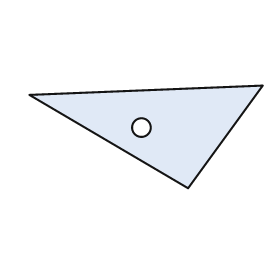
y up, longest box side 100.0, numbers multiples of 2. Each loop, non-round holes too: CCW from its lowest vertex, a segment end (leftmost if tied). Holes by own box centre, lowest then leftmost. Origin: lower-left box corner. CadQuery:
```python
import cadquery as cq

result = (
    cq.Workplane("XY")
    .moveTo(68.0, 0.0)
    .lineTo(100.0, 44.0)
    .lineTo(0.0, 40.0)
    .close()
    .moveTo(48.0, 26.0)
    .circle(4.0)
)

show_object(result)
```